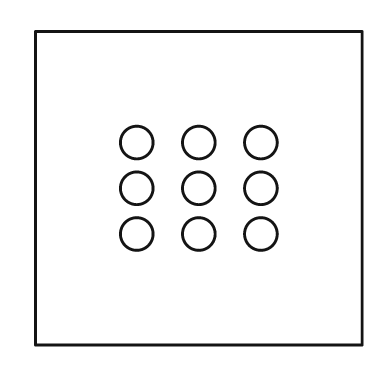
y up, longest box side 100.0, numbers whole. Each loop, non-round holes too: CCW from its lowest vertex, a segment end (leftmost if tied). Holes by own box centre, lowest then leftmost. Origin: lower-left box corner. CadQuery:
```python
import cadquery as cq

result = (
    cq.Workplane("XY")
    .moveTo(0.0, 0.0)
    .lineTo(100.0, 0.0)
    .lineTo(100.0, 96.0)
    .lineTo(0.0, 96.0)
    .close()
    .moveTo(31.0, 34.0)
    .circle(5.0)
    .moveTo(50.0, 34.0)
    .circle(5.0)
    .moveTo(69.0, 34.0)
    .circle(5.0)
    .moveTo(31.0, 48.0)
    .circle(5.0)
    .moveTo(50.0, 48.0)
    .circle(5.0)
    .moveTo(69.0, 48.0)
    .circle(5.0)
    .moveTo(31.0, 62.0)
    .circle(5.0)
    .moveTo(50.0, 62.0)
    .circle(5.0)
    .moveTo(69.0, 62.0)
    .circle(5.0)
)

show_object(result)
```